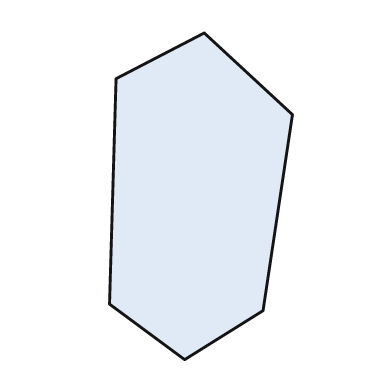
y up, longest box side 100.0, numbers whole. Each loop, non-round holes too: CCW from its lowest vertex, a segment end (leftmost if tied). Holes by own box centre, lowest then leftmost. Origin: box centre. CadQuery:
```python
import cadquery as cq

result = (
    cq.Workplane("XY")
    .moveTo(-5.0, -50.0)
    .lineTo(19.0, -35.0)
    .lineTo(28.0, 25.0)
    .lineTo(1.0, 50.0)
    .lineTo(-26.0, 36.0)
    .lineTo(-28.0, -33.0)
    .close()
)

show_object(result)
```